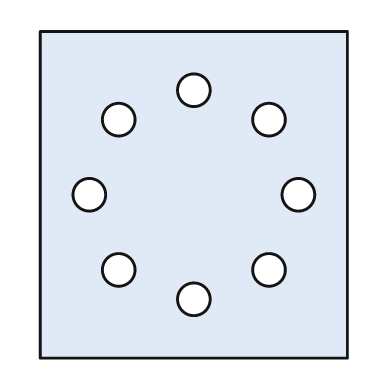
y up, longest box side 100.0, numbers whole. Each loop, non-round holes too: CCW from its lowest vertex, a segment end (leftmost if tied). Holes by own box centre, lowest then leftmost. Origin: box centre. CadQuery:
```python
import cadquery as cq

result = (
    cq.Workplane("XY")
    .moveTo(-47.0, -50.0)
    .lineTo(47.0, -50.0)
    .lineTo(47.0, 50.0)
    .lineTo(-47.0, 50.0)
    .close()
    .moveTo(0.0, -32.0)
    .circle(5.0)
    .moveTo(-23.0, -23.0)
    .circle(5.0)
    .moveTo(23.0, -23.0)
    .circle(5.0)
    .moveTo(-32.0, 0.0)
    .circle(5.0)
    .moveTo(32.0, 0.0)
    .circle(5.0)
    .moveTo(-23.0, 23.0)
    .circle(5.0)
    .moveTo(23.0, 23.0)
    .circle(5.0)
    .moveTo(0.0, 32.0)
    .circle(5.0)
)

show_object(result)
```